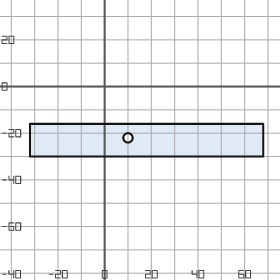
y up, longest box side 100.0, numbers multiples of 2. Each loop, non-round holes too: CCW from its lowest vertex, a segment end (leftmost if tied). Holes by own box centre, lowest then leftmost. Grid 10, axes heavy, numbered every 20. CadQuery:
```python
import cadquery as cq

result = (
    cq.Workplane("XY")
    .moveTo(-32.0, -30.0)
    .lineTo(68.0, -30.0)
    .lineTo(68.0, -16.0)
    .lineTo(-32.0, -16.0)
    .close()
    .moveTo(10.0, -22.0)
    .circle(2.0)
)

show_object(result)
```